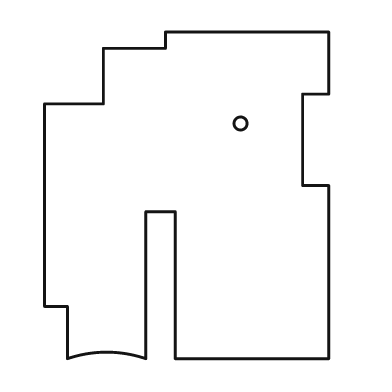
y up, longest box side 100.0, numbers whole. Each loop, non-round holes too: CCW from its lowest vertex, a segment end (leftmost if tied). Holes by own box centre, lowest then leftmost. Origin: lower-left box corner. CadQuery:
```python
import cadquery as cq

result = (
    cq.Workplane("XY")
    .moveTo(7.0, 0.0)
    .threePointArc((19.0, 2.0), (31.0, 0.0))
    .lineTo(31.0, 45.0)
    .lineTo(40.0, 45.0)
    .lineTo(40.0, 0.0)
    .lineTo(87.0, 0.0)
    .lineTo(87.0, 53.0)
    .lineTo(79.0, 53.0)
    .lineTo(79.0, 81.0)
    .lineTo(87.0, 81.0)
    .lineTo(87.0, 100.0)
    .lineTo(37.0, 100.0)
    .lineTo(37.0, 95.0)
    .lineTo(18.0, 95.0)
    .lineTo(18.0, 78.0)
    .lineTo(0.0, 78.0)
    .lineTo(0.0, 16.0)
    .lineTo(7.0, 16.0)
    .close()
    .moveTo(60.0, 72.0)
    .circle(2.0)
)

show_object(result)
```